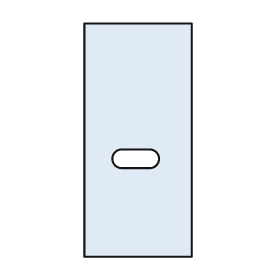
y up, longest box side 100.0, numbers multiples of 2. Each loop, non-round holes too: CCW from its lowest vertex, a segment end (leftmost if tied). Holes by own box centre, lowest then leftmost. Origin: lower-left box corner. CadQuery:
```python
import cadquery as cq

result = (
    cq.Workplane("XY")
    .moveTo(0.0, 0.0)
    .lineTo(46.0, 0.0)
    .lineTo(46.0, 100.0)
    .lineTo(0.0, 100.0)
    .close()
    .moveTo(16.0, 38.0)
    .lineTo(28.0, 38.0)
    .threePointArc((32.0, 42.0), (28.0, 46.0))
    .lineTo(16.0, 46.0)
    .threePointArc((12.0, 42.0), (16.0, 38.0))
    .close()
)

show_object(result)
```